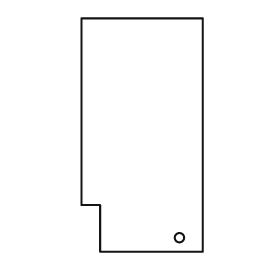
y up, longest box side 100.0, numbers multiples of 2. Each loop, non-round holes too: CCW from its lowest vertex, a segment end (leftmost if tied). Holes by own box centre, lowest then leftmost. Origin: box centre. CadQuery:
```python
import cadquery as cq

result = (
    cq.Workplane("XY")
    .moveTo(-18.0, -50.0)
    .lineTo(26.0, -50.0)
    .lineTo(26.0, 50.0)
    .lineTo(-26.0, 50.0)
    .lineTo(-26.0, -30.0)
    .lineTo(-18.0, -30.0)
    .close()
    .moveTo(16.0, -44.0)
    .circle(2.0)
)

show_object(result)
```